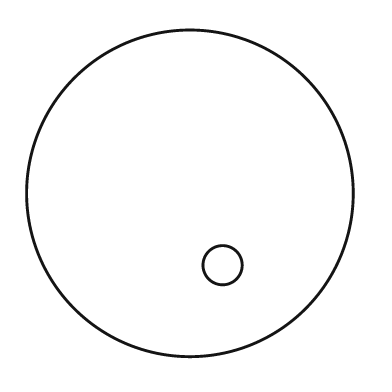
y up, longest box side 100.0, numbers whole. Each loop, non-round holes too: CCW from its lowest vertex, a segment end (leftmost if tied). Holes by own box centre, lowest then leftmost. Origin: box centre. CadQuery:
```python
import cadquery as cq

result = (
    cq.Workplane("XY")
    .moveTo(0.0, 0.0)
    .circle(50.0)
    .moveTo(10.0, -22.0)
    .circle(6.0)
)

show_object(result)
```